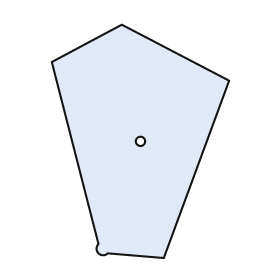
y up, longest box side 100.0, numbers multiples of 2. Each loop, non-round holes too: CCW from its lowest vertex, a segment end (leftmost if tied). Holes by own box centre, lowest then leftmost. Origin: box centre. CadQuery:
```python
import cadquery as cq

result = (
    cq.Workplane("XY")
    .moveTo(10.0, -50.0)
    .lineTo(38.0, 26.0)
    .lineTo(-8.0, 50.0)
    .lineTo(-38.0, 34.0)
    .lineTo(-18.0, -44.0)
    .threePointArc((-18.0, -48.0), (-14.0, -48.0))
    .close()
    .moveTo(0.0, 0.0)
    .circle(2.0)
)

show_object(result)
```